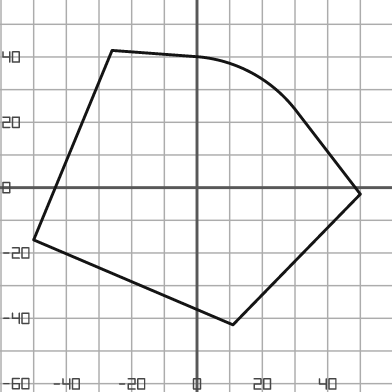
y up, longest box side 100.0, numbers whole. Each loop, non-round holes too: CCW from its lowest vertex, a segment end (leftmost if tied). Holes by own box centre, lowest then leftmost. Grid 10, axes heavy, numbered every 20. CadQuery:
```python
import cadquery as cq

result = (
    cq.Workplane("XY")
    .moveTo(11.0, -42.0)
    .lineTo(50.0, -2.0)
    .lineTo(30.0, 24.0)
    .threePointArc((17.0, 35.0), (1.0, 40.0))
    .lineTo(-26.0, 42.0)
    .lineTo(-50.0, -16.0)
    .close()
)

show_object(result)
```